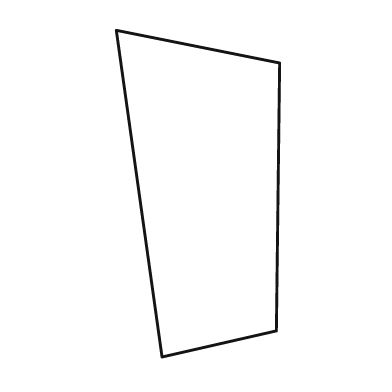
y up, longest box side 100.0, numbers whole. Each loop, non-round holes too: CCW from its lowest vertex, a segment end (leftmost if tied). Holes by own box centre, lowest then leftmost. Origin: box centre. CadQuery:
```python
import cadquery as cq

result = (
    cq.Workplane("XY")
    .moveTo(-11.0, -50.0)
    .lineTo(24.0, -42.0)
    .lineTo(25.0, 40.0)
    .lineTo(-25.0, 50.0)
    .close()
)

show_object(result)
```